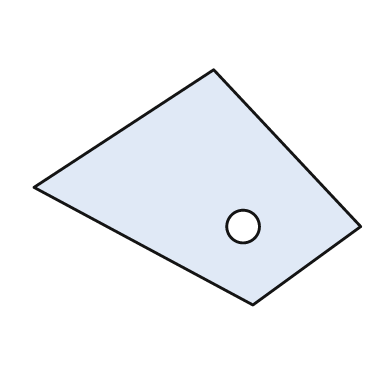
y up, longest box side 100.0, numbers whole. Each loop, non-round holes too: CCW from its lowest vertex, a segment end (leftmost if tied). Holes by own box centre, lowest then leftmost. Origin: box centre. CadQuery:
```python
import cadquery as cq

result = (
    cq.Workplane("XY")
    .moveTo(17.0, -36.0)
    .lineTo(50.0, -12.0)
    .lineTo(5.0, 36.0)
    .lineTo(-50.0, 0.0)
    .close()
    .moveTo(14.0, -12.0)
    .circle(5.0)
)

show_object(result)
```